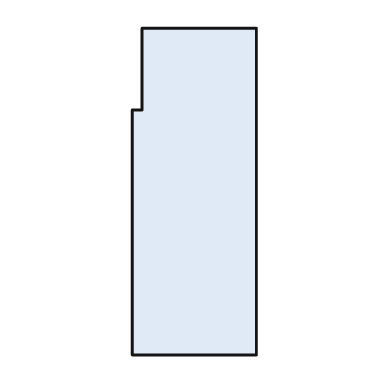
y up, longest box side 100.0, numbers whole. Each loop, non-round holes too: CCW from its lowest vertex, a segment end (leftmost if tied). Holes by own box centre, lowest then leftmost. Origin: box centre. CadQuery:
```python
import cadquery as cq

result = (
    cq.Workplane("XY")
    .moveTo(-19.0, -50.0)
    .lineTo(19.0, -50.0)
    .lineTo(19.0, 50.0)
    .lineTo(-16.0, 50.0)
    .lineTo(-16.0, 25.0)
    .lineTo(-19.0, 25.0)
    .close()
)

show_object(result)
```